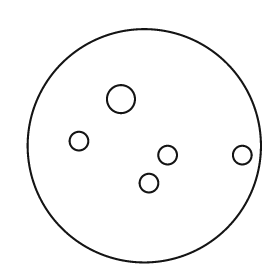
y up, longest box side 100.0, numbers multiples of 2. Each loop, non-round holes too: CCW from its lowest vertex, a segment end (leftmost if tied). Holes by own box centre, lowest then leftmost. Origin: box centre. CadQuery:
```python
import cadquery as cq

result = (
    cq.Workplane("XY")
    .moveTo(0.0, 0.0)
    .circle(50.0)
    .moveTo(2.0, -16.0)
    .circle(4.0)
    .moveTo(10.0, -4.0)
    .circle(4.0)
    .moveTo(42.0, -4.0)
    .circle(4.0)
    .moveTo(-28.0, 2.0)
    .circle(4.0)
    .moveTo(-10.0, 20.0)
    .circle(6.0)
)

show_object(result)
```